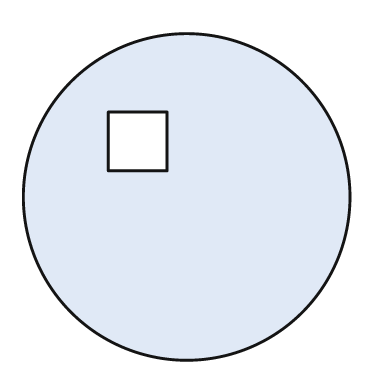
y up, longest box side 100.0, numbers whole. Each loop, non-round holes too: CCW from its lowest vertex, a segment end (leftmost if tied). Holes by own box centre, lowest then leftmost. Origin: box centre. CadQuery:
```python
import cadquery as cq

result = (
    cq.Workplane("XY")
    .moveTo(0.0, 0.0)
    .circle(50.0)
    .moveTo(-24.0, 8.0)
    .lineTo(-6.0, 8.0)
    .lineTo(-6.0, 26.0)
    .lineTo(-24.0, 26.0)
    .close()
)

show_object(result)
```